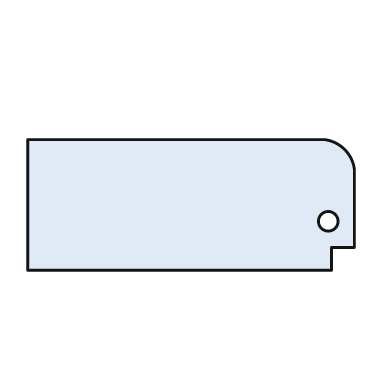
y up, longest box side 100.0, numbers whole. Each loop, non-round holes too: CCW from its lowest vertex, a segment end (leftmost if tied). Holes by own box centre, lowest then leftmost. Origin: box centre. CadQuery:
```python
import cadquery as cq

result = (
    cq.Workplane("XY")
    .moveTo(-50.0, -20.0)
    .lineTo(43.0, -20.0)
    .lineTo(43.0, -13.0)
    .lineTo(50.0, -13.0)
    .lineTo(50.0, 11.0)
    .threePointArc((47.0, 17.0), (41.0, 20.0))
    .lineTo(-50.0, 20.0)
    .close()
    .moveTo(42.0, -5.0)
    .circle(3.0)
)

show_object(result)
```